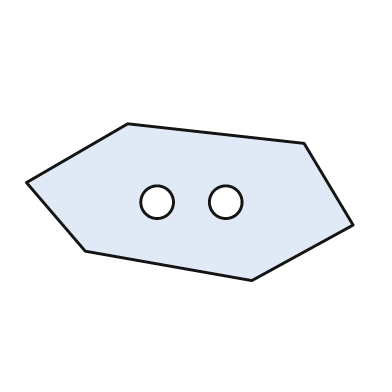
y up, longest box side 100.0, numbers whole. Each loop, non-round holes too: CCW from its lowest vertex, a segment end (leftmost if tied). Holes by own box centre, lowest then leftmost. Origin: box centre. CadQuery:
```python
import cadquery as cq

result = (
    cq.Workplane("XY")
    .moveTo(19.0, -24.0)
    .lineTo(50.0, -7.0)
    .lineTo(35.0, 18.0)
    .lineTo(-19.0, 24.0)
    .lineTo(-50.0, 6.0)
    .lineTo(-32.0, -15.0)
    .close()
    .moveTo(-10.0, 0.0)
    .circle(5.0)
    .moveTo(11.0, 0.0)
    .circle(5.0)
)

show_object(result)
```